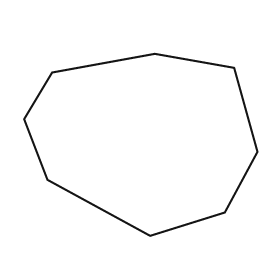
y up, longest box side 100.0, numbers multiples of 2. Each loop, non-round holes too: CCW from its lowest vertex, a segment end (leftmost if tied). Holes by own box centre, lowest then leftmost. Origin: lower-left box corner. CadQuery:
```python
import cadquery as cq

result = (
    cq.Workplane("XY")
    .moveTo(54.0, 0.0)
    .lineTo(86.0, 10.0)
    .lineTo(100.0, 36.0)
    .lineTo(90.0, 72.0)
    .lineTo(56.0, 78.0)
    .lineTo(12.0, 70.0)
    .lineTo(0.0, 50.0)
    .lineTo(10.0, 24.0)
    .close()
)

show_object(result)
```